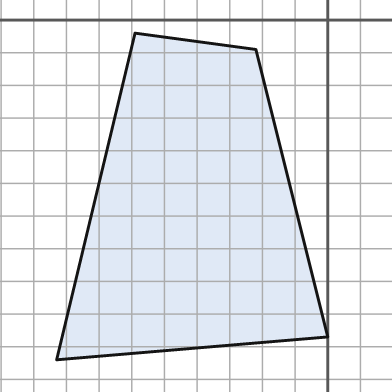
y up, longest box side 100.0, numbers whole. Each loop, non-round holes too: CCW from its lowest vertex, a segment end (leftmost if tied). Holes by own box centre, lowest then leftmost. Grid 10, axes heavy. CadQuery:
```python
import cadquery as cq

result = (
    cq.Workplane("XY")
    .moveTo(-83.0, -104.0)
    .lineTo(0.0, -97.0)
    .lineTo(-22.0, -9.0)
    .lineTo(-59.0, -4.0)
    .close()
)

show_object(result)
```